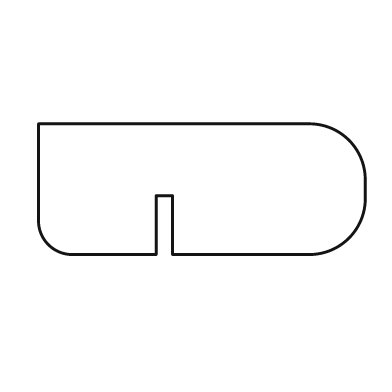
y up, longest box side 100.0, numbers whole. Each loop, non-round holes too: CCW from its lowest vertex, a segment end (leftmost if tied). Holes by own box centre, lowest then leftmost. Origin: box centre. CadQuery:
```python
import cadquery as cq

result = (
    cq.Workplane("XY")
    .moveTo(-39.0, -20.0)
    .lineTo(-14.0, -20.0)
    .lineTo(-14.0, -2.0)
    .lineTo(-9.0, -2.0)
    .lineTo(-9.0, -20.0)
    .lineTo(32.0, -20.0)
    .threePointArc((45.0, -15.0), (50.0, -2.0))
    .lineTo(50.0, 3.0)
    .threePointArc((45.0, 15.0), (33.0, 20.0))
    .lineTo(-50.0, 20.0)
    .lineTo(-50.0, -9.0)
    .threePointArc((-47.0, -17.0), (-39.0, -20.0))
    .close()
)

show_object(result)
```